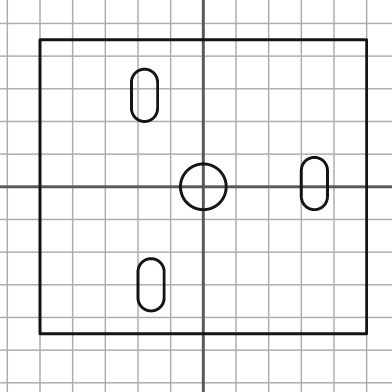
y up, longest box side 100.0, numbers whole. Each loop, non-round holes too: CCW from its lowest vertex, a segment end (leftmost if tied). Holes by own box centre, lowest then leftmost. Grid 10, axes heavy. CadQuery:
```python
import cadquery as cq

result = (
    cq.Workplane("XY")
    .moveTo(-50.0, -45.0)
    .lineTo(50.0, -45.0)
    .lineTo(50.0, 45.0)
    .lineTo(-50.0, 45.0)
    .close()
    .moveTo(-20.0, -34.0)
    .threePointArc((-16.0, -38.0), (-12.0, -34.0))
    .lineTo(-12.0, -26.0)
    .threePointArc((-16.0, -22.0), (-20.0, -26.0))
    .close()
    .moveTo(0.0, 0.0)
    .circle(7.0)
    .moveTo(30.0, -3.0)
    .threePointArc((34.0, -7.0), (38.0, -3.0))
    .lineTo(38.0, 5.0)
    .threePointArc((34.0, 9.0), (30.0, 5.0))
    .close()
    .moveTo(-22.0, 24.0)
    .threePointArc((-18.0, 20.0), (-14.0, 24.0))
    .lineTo(-14.0, 32.0)
    .threePointArc((-18.0, 36.0), (-22.0, 32.0))
    .close()
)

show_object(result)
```